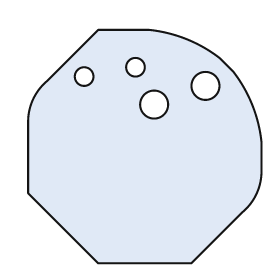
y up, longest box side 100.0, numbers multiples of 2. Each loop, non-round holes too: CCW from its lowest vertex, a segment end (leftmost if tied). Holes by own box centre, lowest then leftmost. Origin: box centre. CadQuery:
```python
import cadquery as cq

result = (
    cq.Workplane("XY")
    .moveTo(-20.0, -50.0)
    .lineTo(20.0, -50.0)
    .lineTo(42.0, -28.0)
    .threePointArc((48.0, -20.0), (50.0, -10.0))
    .lineTo(50.0, 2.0)
    .threePointArc((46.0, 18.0), (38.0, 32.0))
    .lineTo(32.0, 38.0)
    .threePointArc((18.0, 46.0), (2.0, 50.0))
    .lineTo(-20.0, 50.0)
    .lineTo(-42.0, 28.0)
    .threePointArc((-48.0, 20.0), (-50.0, 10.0))
    .lineTo(-50.0, -20.0)
    .close()
    .moveTo(4.0, 18.0)
    .circle(6.0)
    .moveTo(26.0, 26.0)
    .circle(6.0)
    .moveTo(-26.0, 30.0)
    .circle(4.0)
    .moveTo(-4.0, 34.0)
    .circle(4.0)
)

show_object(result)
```